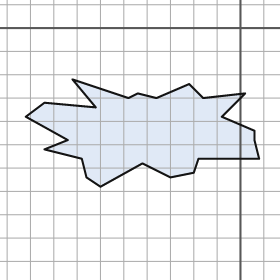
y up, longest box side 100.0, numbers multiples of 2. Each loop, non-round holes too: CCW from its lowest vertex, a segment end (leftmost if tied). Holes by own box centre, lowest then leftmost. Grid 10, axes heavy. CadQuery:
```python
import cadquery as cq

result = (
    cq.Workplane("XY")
    .moveTo(-60.0, -68.0)
    .lineTo(-42.0, -58.0)
    .lineTo(-30.0, -64.0)
    .lineTo(-20.0, -62.0)
    .lineTo(-18.0, -56.0)
    .lineTo(8.0, -56.0)
    .lineTo(6.0, -48.0)
    .lineTo(6.0, -44.0)
    .lineTo(-8.0, -38.0)
    .lineTo(2.0, -28.0)
    .lineTo(-16.0, -30.0)
    .lineTo(-22.0, -24.0)
    .lineTo(-36.0, -30.0)
    .lineTo(-44.0, -28.0)
    .lineTo(-48.0, -30.0)
    .lineTo(-72.0, -22.0)
    .lineTo(-62.0, -34.0)
    .lineTo(-84.0, -32.0)
    .lineTo(-92.0, -38.0)
    .lineTo(-74.0, -48.0)
    .lineTo(-84.0, -52.0)
    .lineTo(-68.0, -56.0)
    .lineTo(-66.0, -64.0)
    .close()
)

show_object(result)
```